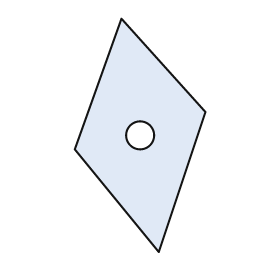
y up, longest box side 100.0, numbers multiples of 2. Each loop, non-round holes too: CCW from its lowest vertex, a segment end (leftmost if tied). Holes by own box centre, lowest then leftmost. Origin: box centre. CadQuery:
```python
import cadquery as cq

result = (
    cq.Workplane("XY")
    .moveTo(8.0, -50.0)
    .lineTo(28.0, 10.0)
    .lineTo(-8.0, 50.0)
    .lineTo(-28.0, -6.0)
    .close()
    .moveTo(0.0, 0.0)
    .circle(6.0)
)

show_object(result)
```